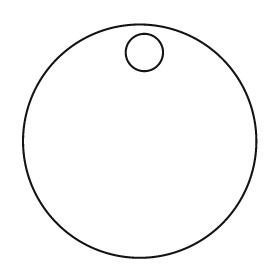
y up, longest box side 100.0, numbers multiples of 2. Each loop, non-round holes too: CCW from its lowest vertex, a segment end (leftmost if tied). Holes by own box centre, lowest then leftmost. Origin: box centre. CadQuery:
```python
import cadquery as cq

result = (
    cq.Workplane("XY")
    .moveTo(0.0, 0.0)
    .circle(50.0)
    .moveTo(2.0, 38.0)
    .circle(8.0)
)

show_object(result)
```